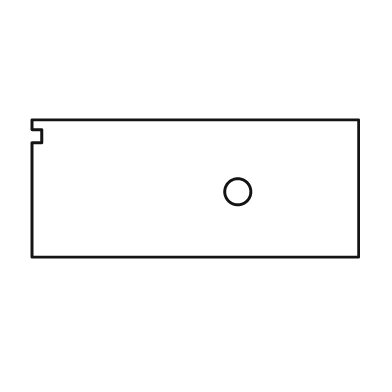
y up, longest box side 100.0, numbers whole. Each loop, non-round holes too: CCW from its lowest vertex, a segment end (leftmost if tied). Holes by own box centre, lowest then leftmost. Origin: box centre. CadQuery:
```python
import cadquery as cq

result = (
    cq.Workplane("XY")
    .moveTo(-50.0, -21.0)
    .lineTo(50.0, -21.0)
    .lineTo(50.0, 21.0)
    .lineTo(-50.0, 21.0)
    .lineTo(-50.0, 18.0)
    .lineTo(-47.0, 18.0)
    .lineTo(-47.0, 14.0)
    .lineTo(-50.0, 14.0)
    .close()
    .moveTo(13.0, -1.0)
    .circle(4.0)
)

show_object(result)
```